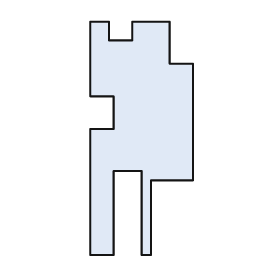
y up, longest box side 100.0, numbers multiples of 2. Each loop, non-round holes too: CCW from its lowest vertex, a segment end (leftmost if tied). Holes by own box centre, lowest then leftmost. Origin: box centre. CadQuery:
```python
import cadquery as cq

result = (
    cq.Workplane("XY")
    .moveTo(-22.0, -50.0)
    .lineTo(-12.0, -50.0)
    .lineTo(-12.0, -14.0)
    .lineTo(0.0, -14.0)
    .lineTo(0.0, -50.0)
    .lineTo(4.0, -50.0)
    .lineTo(4.0, -18.0)
    .lineTo(22.0, -18.0)
    .lineTo(22.0, 32.0)
    .lineTo(12.0, 32.0)
    .lineTo(12.0, 50.0)
    .lineTo(-4.0, 50.0)
    .lineTo(-4.0, 42.0)
    .lineTo(-14.0, 42.0)
    .lineTo(-14.0, 50.0)
    .lineTo(-22.0, 50.0)
    .lineTo(-22.0, 18.0)
    .lineTo(-12.0, 18.0)
    .lineTo(-12.0, 4.0)
    .lineTo(-22.0, 4.0)
    .close()
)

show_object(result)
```